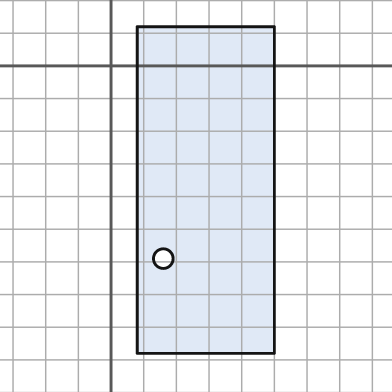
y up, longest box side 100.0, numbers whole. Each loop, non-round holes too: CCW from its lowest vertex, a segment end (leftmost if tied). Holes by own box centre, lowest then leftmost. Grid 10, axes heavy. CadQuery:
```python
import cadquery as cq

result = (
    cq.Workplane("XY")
    .moveTo(8.0, -88.0)
    .lineTo(50.0, -88.0)
    .lineTo(50.0, 12.0)
    .lineTo(8.0, 12.0)
    .close()
    .moveTo(16.0, -59.0)
    .circle(3.0)
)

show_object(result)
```